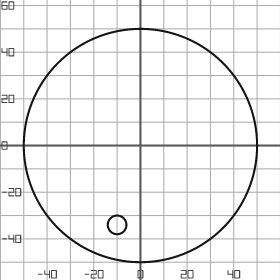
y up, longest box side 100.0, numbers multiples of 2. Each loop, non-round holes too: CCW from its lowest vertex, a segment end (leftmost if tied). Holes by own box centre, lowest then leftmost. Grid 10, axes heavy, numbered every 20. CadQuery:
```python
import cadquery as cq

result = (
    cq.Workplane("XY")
    .moveTo(0.0, 0.0)
    .circle(50.0)
    .moveTo(-10.0, -34.0)
    .circle(4.0)
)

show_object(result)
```